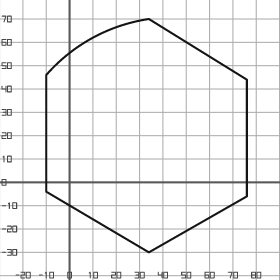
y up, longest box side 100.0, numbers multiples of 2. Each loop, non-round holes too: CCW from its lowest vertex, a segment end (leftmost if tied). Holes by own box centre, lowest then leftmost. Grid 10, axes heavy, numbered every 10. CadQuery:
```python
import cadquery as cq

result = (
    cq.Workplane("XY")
    .moveTo(34.0, -30.0)
    .lineTo(76.0, -6.0)
    .lineTo(76.0, 44.0)
    .lineTo(34.0, 70.0)
    .threePointArc((10.0, 62.0), (-10.0, 46.0))
    .lineTo(-10.0, -4.0)
    .close()
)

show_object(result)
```